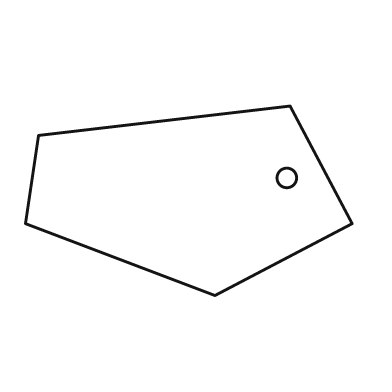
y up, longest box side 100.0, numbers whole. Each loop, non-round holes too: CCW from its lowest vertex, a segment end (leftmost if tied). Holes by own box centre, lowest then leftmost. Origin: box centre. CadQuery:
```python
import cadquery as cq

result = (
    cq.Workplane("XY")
    .moveTo(8.0, -29.0)
    .lineTo(50.0, -7.0)
    .lineTo(31.0, 29.0)
    .lineTo(-46.0, 20.0)
    .lineTo(-50.0, -7.0)
    .close()
    .moveTo(30.0, 7.0)
    .circle(3.0)
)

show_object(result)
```